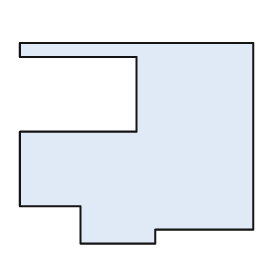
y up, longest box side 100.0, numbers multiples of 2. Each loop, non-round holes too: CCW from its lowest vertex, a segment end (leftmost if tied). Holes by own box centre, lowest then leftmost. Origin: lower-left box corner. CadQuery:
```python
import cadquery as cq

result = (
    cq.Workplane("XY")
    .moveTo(26.0, 0.0)
    .lineTo(58.0, 0.0)
    .lineTo(58.0, 6.0)
    .lineTo(100.0, 6.0)
    .lineTo(100.0, 86.0)
    .lineTo(0.0, 86.0)
    .lineTo(0.0, 80.0)
    .lineTo(50.0, 80.0)
    .lineTo(50.0, 48.0)
    .lineTo(0.0, 48.0)
    .lineTo(0.0, 16.0)
    .lineTo(26.0, 16.0)
    .close()
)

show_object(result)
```